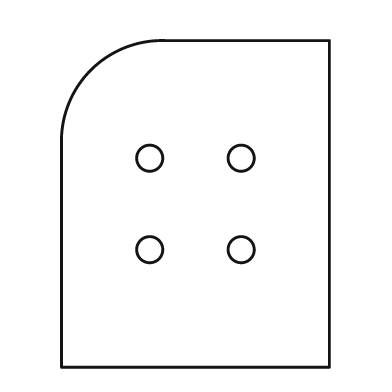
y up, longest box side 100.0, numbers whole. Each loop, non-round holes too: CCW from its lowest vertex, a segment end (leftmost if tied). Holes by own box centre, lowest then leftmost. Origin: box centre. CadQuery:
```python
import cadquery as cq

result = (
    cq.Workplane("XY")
    .moveTo(-41.0, -50.0)
    .lineTo(41.0, -50.0)
    .lineTo(41.0, 50.0)
    .lineTo(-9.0, 50.0)
    .threePointArc((-32.0, 41.0), (-41.0, 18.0))
    .close()
    .moveTo(-14.0, -14.0)
    .circle(4.0)
    .moveTo(14.0, -14.0)
    .circle(4.0)
    .moveTo(-14.0, 14.0)
    .circle(4.0)
    .moveTo(14.0, 14.0)
    .circle(4.0)
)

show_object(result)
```